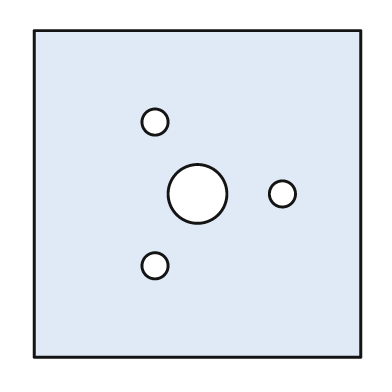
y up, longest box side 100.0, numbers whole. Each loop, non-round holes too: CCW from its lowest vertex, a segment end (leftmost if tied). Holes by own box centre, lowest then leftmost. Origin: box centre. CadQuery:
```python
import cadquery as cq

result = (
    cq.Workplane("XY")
    .moveTo(-50.0, -50.0)
    .lineTo(50.0, -50.0)
    .lineTo(50.0, 50.0)
    .lineTo(-50.0, 50.0)
    .close()
    .moveTo(-13.0, -22.0)
    .circle(4.0)
    .moveTo(0.0, 0.0)
    .circle(9.0)
    .moveTo(26.0, 0.0)
    .circle(4.0)
    .moveTo(-13.0, 22.0)
    .circle(4.0)
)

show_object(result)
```